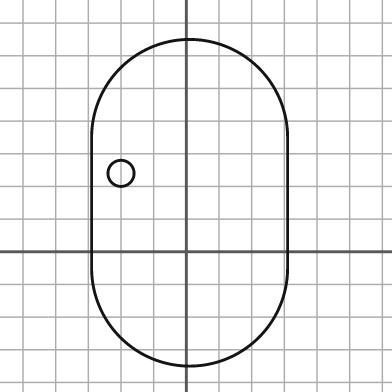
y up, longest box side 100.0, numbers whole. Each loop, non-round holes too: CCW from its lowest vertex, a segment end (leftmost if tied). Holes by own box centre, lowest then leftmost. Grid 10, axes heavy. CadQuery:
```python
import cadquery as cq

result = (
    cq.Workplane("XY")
    .moveTo(-29.0, -5.0)
    .threePointArc((1.0, -35.0), (31.0, -5.0))
    .lineTo(31.0, 35.0)
    .threePointArc((1.0, 65.0), (-29.0, 35.0))
    .close()
    .moveTo(-20.0, 24.0)
    .circle(4.0)
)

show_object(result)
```